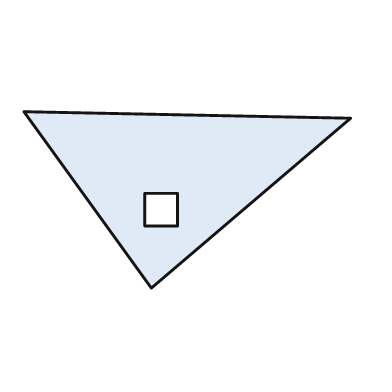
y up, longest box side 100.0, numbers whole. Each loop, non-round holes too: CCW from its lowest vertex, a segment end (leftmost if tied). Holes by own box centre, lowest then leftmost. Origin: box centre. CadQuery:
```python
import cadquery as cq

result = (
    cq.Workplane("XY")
    .moveTo(-11.0, -27.0)
    .lineTo(50.0, 25.0)
    .lineTo(-50.0, 27.0)
    .close()
    .moveTo(-13.0, -8.0)
    .lineTo(-3.0, -8.0)
    .lineTo(-3.0, 2.0)
    .lineTo(-13.0, 2.0)
    .close()
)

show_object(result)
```